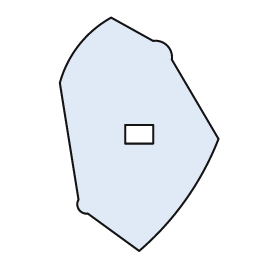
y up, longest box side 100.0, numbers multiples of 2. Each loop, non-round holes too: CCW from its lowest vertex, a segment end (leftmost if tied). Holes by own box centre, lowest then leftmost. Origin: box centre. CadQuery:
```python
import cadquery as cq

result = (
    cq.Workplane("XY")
    .moveTo(0.0, -50.0)
    .threePointArc((20.0, -28.0), (34.0, -2.0))
    .lineTo(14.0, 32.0)
    .threePointArc((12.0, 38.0), (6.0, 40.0))
    .lineTo(-12.0, 50.0)
    .threePointArc((-26.0, 38.0), (-34.0, 22.0))
    .lineTo(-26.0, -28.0)
    .threePointArc((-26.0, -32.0), (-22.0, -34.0))
    .close()
    .moveTo(-6.0, -4.0)
    .lineTo(6.0, -4.0)
    .lineTo(6.0, 4.0)
    .lineTo(-6.0, 4.0)
    .close()
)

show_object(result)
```